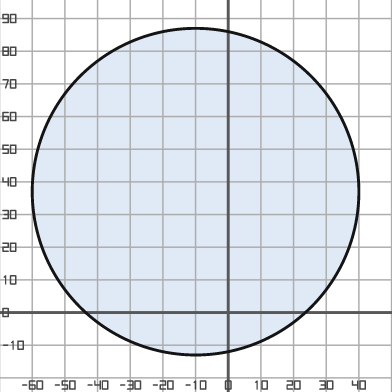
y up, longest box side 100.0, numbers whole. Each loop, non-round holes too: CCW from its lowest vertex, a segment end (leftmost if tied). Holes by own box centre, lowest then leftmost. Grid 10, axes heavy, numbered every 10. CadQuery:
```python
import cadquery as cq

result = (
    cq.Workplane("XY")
    .moveTo(-10.0, 37.0)
    .circle(50.0)
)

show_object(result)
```